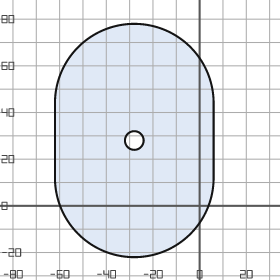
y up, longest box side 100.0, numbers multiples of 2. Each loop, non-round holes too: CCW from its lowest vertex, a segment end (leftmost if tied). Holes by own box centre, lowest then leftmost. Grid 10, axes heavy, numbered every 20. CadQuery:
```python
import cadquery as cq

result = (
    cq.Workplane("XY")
    .moveTo(-62.0, 12.0)
    .threePointArc((-28.0, -22.0), (6.0, 12.0))
    .lineTo(6.0, 44.0)
    .threePointArc((-28.0, 78.0), (-62.0, 44.0))
    .close()
    .moveTo(-28.0, 28.0)
    .circle(4.0)
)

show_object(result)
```